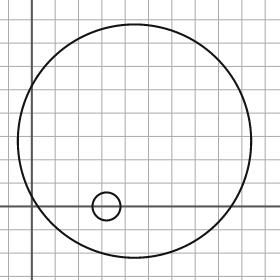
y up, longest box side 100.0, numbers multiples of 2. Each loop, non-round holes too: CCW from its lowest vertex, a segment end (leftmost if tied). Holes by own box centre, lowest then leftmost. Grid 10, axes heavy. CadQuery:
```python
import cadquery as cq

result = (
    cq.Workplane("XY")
    .moveTo(44.0, 28.0)
    .circle(50.0)
    .moveTo(32.0, 0.0)
    .circle(6.0)
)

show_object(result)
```